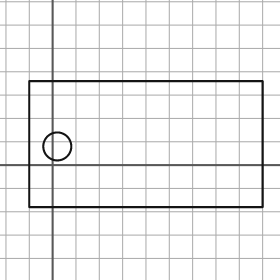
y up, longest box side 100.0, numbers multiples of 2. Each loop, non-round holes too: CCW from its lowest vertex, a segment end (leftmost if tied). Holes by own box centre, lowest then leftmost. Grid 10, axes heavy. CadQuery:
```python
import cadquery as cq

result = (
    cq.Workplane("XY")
    .moveTo(-10.0, -18.0)
    .lineTo(90.0, -18.0)
    .lineTo(90.0, 36.0)
    .lineTo(-10.0, 36.0)
    .close()
    .moveTo(2.0, 8.0)
    .circle(6.0)
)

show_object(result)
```